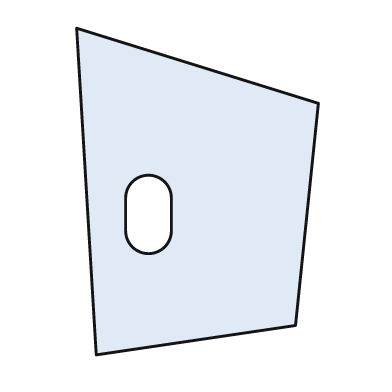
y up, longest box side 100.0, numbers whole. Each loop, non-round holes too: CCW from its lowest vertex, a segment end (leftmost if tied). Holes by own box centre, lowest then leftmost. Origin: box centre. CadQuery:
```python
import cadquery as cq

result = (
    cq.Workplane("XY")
    .moveTo(-31.0, -50.0)
    .lineTo(30.0, -41.0)
    .lineTo(37.0, 27.0)
    .lineTo(-37.0, 50.0)
    .close()
    .moveTo(-22.0, -12.0)
    .threePointArc((-15.0, -19.0), (-8.0, -12.0))
    .lineTo(-8.0, -2.0)
    .threePointArc((-15.0, 5.0), (-22.0, -2.0))
    .close()
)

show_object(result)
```